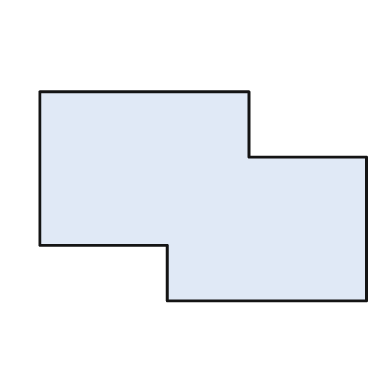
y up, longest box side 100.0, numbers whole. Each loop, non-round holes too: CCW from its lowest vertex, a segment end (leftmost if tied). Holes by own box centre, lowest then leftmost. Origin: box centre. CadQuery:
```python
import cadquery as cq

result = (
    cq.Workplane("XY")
    .moveTo(-11.0, -32.0)
    .lineTo(50.0, -32.0)
    .lineTo(50.0, 12.0)
    .lineTo(14.0, 12.0)
    .lineTo(14.0, 32.0)
    .lineTo(-50.0, 32.0)
    .lineTo(-50.0, -15.0)
    .lineTo(-11.0, -15.0)
    .close()
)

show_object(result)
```